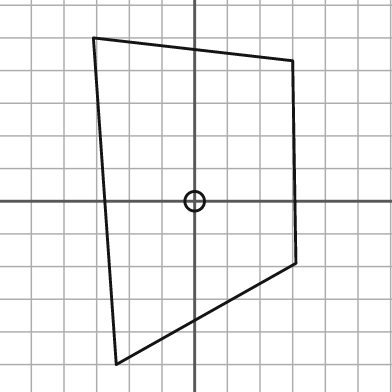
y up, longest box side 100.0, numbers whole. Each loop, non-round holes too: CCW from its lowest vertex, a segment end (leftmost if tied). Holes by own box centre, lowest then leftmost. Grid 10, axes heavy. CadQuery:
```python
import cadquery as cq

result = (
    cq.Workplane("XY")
    .moveTo(-24.0, -50.0)
    .lineTo(31.0, -19.0)
    .lineTo(30.0, 43.0)
    .lineTo(-31.0, 50.0)
    .close()
    .moveTo(0.0, 0.0)
    .circle(3.0)
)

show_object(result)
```